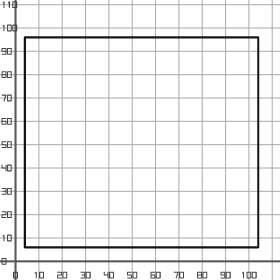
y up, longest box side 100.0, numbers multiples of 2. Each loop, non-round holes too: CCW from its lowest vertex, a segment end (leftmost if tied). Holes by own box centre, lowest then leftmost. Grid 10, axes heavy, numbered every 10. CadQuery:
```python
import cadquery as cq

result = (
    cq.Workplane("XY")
    .moveTo(4.0, 6.0)
    .lineTo(104.0, 6.0)
    .lineTo(104.0, 96.0)
    .lineTo(4.0, 96.0)
    .close()
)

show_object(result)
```